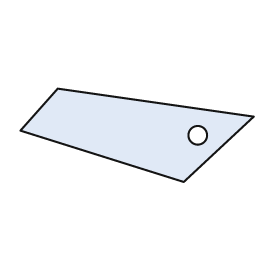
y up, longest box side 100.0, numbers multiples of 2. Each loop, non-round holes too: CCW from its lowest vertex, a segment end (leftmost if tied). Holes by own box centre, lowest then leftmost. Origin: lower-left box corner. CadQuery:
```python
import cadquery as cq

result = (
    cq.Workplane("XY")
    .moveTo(70.0, 0.0)
    .lineTo(100.0, 28.0)
    .lineTo(16.0, 40.0)
    .lineTo(0.0, 22.0)
    .close()
    .moveTo(76.0, 20.0)
    .circle(4.0)
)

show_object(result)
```